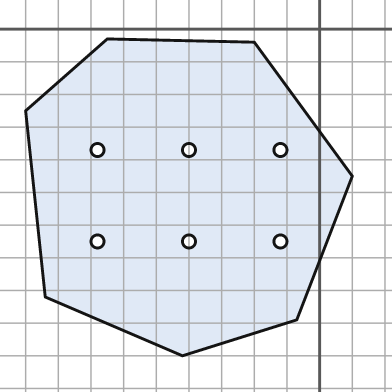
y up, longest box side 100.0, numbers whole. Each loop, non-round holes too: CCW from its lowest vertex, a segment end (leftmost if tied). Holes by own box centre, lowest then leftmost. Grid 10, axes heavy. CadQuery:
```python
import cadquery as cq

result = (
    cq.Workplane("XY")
    .moveTo(-42.0, -100.0)
    .lineTo(-7.0, -89.0)
    .lineTo(10.0, -45.0)
    .lineTo(-20.0, -4.0)
    .lineTo(-65.0, -3.0)
    .lineTo(-90.0, -25.0)
    .lineTo(-84.0, -82.0)
    .close()
    .moveTo(-68.0, -65.0)
    .circle(2.0)
    .moveTo(-40.0, -65.0)
    .circle(2.0)
    .moveTo(-12.0, -65.0)
    .circle(2.0)
    .moveTo(-68.0, -37.0)
    .circle(2.0)
    .moveTo(-40.0, -37.0)
    .circle(2.0)
    .moveTo(-12.0, -37.0)
    .circle(2.0)
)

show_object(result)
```